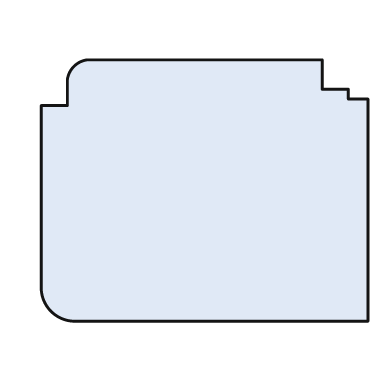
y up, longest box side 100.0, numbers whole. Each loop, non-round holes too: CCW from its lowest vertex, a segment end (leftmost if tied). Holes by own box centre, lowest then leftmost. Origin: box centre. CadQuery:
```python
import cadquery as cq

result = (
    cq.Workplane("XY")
    .moveTo(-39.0, -40.0)
    .lineTo(50.0, -40.0)
    .lineTo(50.0, 28.0)
    .lineTo(44.0, 28.0)
    .lineTo(44.0, 31.0)
    .lineTo(36.0, 31.0)
    .lineTo(36.0, 40.0)
    .lineTo(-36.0, 40.0)
    .threePointArc((-40.0, 38.0), (-42.0, 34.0))
    .lineTo(-42.0, 26.0)
    .lineTo(-50.0, 26.0)
    .lineTo(-50.0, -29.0)
    .threePointArc((-47.0, -37.0), (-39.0, -40.0))
    .close()
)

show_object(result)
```